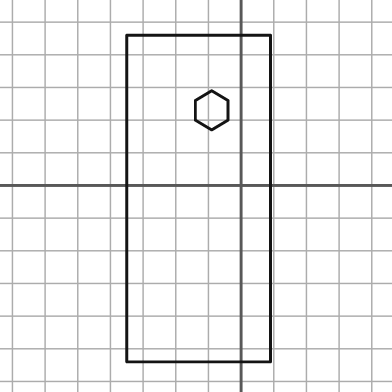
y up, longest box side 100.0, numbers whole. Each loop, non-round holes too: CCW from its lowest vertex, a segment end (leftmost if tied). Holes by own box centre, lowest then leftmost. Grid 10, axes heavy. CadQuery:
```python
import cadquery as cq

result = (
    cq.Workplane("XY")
    .moveTo(-35.0, -54.0)
    .lineTo(9.0, -54.0)
    .lineTo(9.0, 46.0)
    .lineTo(-35.0, 46.0)
    .close()
    .moveTo(-9.0, 17.0)
    .lineTo(-4.0, 20.0)
    .lineTo(-4.0, 26.0)
    .lineTo(-9.0, 29.0)
    .lineTo(-14.0, 26.0)
    .lineTo(-14.0, 20.0)
    .close()
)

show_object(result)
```